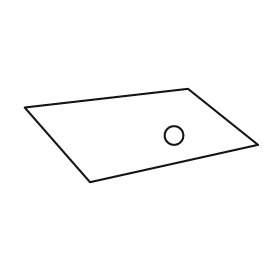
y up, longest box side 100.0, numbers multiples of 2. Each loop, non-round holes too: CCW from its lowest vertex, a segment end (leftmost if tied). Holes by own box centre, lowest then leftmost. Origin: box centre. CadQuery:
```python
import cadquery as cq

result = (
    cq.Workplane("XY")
    .moveTo(-22.0, -20.0)
    .lineTo(50.0, -4.0)
    .lineTo(20.0, 20.0)
    .lineTo(-50.0, 12.0)
    .close()
    .moveTo(14.0, 0.0)
    .circle(4.0)
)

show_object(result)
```